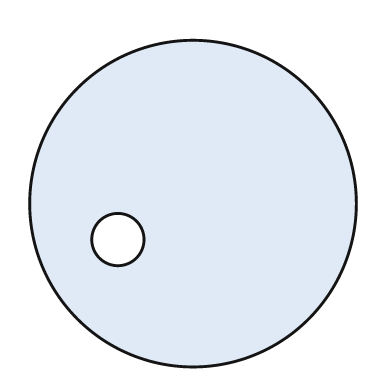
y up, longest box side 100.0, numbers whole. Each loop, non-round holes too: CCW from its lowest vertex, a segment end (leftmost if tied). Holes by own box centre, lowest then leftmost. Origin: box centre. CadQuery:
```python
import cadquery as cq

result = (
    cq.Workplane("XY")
    .moveTo(0.0, 0.0)
    .circle(50.0)
    .moveTo(-23.0, -11.0)
    .circle(8.0)
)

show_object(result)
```